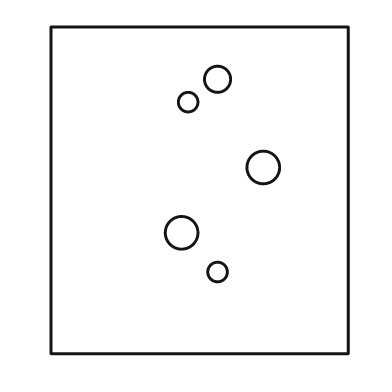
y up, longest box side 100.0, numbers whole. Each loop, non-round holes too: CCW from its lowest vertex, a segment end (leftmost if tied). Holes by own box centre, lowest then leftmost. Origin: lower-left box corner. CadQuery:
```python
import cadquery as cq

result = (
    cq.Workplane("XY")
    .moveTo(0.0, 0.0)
    .lineTo(91.0, 0.0)
    .lineTo(91.0, 100.0)
    .lineTo(0.0, 100.0)
    .close()
    .moveTo(51.0, 25.0)
    .circle(3.0)
    .moveTo(40.0, 37.0)
    .circle(5.0)
    .moveTo(65.0, 57.0)
    .circle(5.0)
    .moveTo(42.0, 77.0)
    .circle(3.0)
    .moveTo(51.0, 84.0)
    .circle(4.0)
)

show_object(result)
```